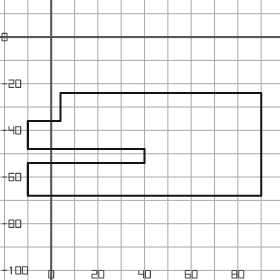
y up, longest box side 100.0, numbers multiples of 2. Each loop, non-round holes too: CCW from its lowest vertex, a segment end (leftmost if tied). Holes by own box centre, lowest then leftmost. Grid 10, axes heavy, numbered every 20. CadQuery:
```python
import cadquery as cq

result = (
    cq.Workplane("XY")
    .moveTo(-10.0, -68.0)
    .lineTo(90.0, -68.0)
    .lineTo(90.0, -24.0)
    .lineTo(4.0, -24.0)
    .lineTo(4.0, -36.0)
    .lineTo(-10.0, -36.0)
    .lineTo(-10.0, -48.0)
    .lineTo(40.0, -48.0)
    .lineTo(40.0, -54.0)
    .lineTo(-10.0, -54.0)
    .close()
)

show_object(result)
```